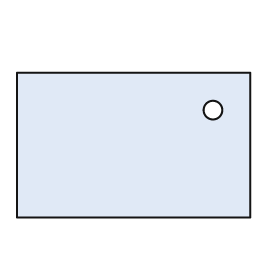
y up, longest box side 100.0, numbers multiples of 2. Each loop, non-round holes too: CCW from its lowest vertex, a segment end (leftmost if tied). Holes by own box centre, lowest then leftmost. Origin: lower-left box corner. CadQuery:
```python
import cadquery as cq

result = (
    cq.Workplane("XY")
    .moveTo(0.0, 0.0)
    .lineTo(100.0, 0.0)
    .lineTo(100.0, 62.0)
    .lineTo(0.0, 62.0)
    .close()
    .moveTo(84.0, 46.0)
    .circle(4.0)
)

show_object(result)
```